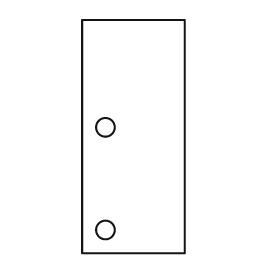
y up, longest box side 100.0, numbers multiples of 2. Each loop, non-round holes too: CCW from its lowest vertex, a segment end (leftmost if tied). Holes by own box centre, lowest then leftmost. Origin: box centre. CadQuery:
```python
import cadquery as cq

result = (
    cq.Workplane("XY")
    .moveTo(-22.0, -50.0)
    .lineTo(22.0, -50.0)
    .lineTo(22.0, 50.0)
    .lineTo(-22.0, 50.0)
    .close()
    .moveTo(-12.0, -40.0)
    .circle(4.0)
    .moveTo(-12.0, 4.0)
    .circle(4.0)
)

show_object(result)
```